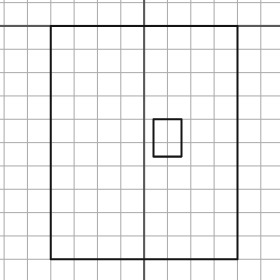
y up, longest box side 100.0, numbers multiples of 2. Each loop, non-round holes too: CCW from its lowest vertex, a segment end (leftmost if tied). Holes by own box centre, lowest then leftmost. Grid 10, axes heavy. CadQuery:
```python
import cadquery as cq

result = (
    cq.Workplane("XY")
    .moveTo(-40.0, -100.0)
    .lineTo(40.0, -100.0)
    .lineTo(40.0, 0.0)
    .lineTo(-40.0, 0.0)
    .close()
    .moveTo(4.0, -56.0)
    .lineTo(16.0, -56.0)
    .lineTo(16.0, -40.0)
    .lineTo(4.0, -40.0)
    .close()
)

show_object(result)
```